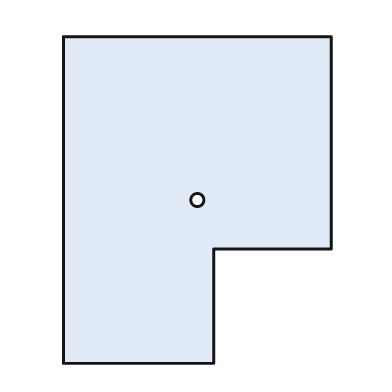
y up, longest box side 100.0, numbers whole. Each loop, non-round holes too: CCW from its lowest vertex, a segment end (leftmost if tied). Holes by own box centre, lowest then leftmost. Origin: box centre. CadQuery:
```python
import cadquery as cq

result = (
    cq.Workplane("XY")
    .moveTo(-41.0, -50.0)
    .lineTo(5.0, -50.0)
    .lineTo(5.0, -15.0)
    .lineTo(41.0, -15.0)
    .lineTo(41.0, 50.0)
    .lineTo(-41.0, 50.0)
    .close()
    .moveTo(0.0, 0.0)
    .circle(2.0)
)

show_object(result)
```